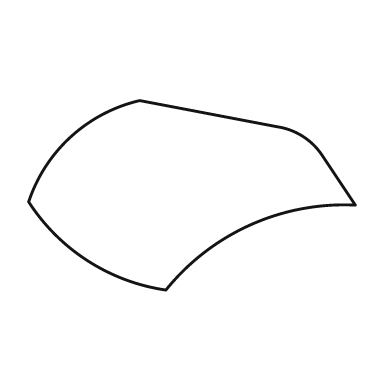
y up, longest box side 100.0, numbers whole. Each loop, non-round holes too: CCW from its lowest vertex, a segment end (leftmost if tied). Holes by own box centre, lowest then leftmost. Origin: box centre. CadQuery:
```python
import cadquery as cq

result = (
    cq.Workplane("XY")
    .moveTo(-8.0, -29.0)
    .threePointArc((18.0, -9.0), (50.0, -3.0))
    .lineTo(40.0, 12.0)
    .threePointArc((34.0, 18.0), (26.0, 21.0))
    .lineTo(-16.0, 29.0)
    .threePointArc((-37.0, 18.0), (-50.0, -2.0))
    .threePointArc((-32.0, -20.0), (-8.0, -29.0))
    .close()
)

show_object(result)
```